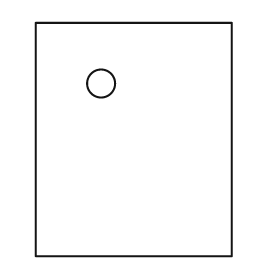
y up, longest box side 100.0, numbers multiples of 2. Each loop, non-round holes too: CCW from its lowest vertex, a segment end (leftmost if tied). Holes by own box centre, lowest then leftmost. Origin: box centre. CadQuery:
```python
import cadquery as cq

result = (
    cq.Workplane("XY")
    .moveTo(-42.0, -50.0)
    .lineTo(42.0, -50.0)
    .lineTo(42.0, 50.0)
    .lineTo(-42.0, 50.0)
    .close()
    .moveTo(-14.0, 24.0)
    .circle(6.0)
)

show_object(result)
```